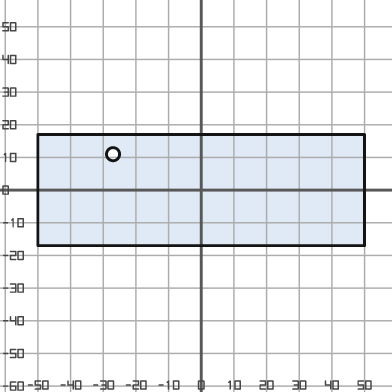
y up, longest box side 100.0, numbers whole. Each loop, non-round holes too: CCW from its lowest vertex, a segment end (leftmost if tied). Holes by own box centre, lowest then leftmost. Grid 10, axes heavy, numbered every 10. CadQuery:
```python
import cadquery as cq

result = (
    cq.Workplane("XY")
    .moveTo(-50.0, -17.0)
    .lineTo(50.0, -17.0)
    .lineTo(50.0, 17.0)
    .lineTo(-50.0, 17.0)
    .close()
    .moveTo(-27.0, 11.0)
    .circle(2.0)
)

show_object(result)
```